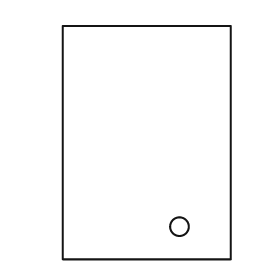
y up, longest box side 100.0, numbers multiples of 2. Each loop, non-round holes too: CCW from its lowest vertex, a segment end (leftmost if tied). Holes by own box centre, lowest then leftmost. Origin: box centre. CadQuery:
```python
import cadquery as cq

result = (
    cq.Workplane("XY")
    .moveTo(-36.0, -50.0)
    .lineTo(36.0, -50.0)
    .lineTo(36.0, 50.0)
    .lineTo(-36.0, 50.0)
    .close()
    .moveTo(14.0, -36.0)
    .circle(4.0)
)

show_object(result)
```